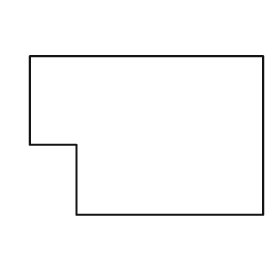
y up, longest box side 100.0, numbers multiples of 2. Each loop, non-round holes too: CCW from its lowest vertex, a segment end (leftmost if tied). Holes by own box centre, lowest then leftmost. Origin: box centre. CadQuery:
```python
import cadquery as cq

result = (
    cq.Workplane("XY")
    .moveTo(-30.0, -34.0)
    .lineTo(50.0, -34.0)
    .lineTo(50.0, 34.0)
    .lineTo(-50.0, 34.0)
    .lineTo(-50.0, -4.0)
    .lineTo(-30.0, -4.0)
    .close()
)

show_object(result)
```